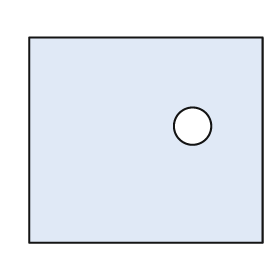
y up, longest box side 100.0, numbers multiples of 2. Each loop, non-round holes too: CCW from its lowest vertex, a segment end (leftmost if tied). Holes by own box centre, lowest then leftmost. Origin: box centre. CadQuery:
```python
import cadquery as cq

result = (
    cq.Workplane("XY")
    .moveTo(-50.0, -44.0)
    .lineTo(50.0, -44.0)
    .lineTo(50.0, 44.0)
    .lineTo(-50.0, 44.0)
    .close()
    .moveTo(20.0, 6.0)
    .circle(8.0)
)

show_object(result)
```